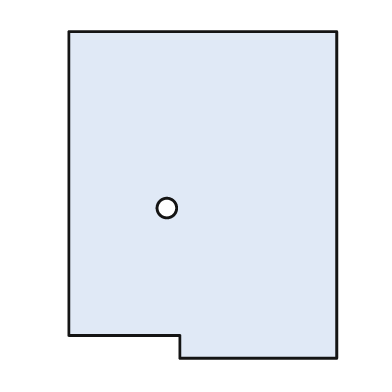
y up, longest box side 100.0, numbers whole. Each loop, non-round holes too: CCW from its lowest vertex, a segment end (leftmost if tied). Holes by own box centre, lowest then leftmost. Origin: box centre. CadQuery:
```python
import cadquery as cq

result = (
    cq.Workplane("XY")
    .moveTo(-7.0, -50.0)
    .lineTo(41.0, -50.0)
    .lineTo(41.0, 50.0)
    .lineTo(-41.0, 50.0)
    .lineTo(-41.0, -43.0)
    .lineTo(-7.0, -43.0)
    .close()
    .moveTo(-11.0, -4.0)
    .circle(3.0)
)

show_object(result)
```